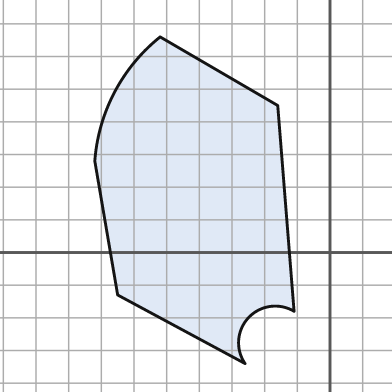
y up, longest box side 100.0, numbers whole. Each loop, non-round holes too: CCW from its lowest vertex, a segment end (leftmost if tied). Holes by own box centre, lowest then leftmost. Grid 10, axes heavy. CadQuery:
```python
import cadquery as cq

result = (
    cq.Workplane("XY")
    .moveTo(-26.0, -34.0)
    .threePointArc((-25.0, -20.0), (-11.0, -18.0))
    .lineTo(-16.0, 45.0)
    .lineTo(-52.0, 66.0)
    .threePointArc((-66.0, 49.0), (-72.0, 28.0))
    .lineTo(-65.0, -13.0)
    .close()
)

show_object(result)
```